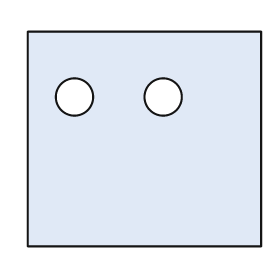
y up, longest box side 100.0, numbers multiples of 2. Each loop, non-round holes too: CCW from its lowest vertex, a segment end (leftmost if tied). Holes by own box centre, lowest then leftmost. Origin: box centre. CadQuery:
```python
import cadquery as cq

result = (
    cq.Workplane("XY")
    .moveTo(-50.0, -46.0)
    .lineTo(50.0, -46.0)
    .lineTo(50.0, 46.0)
    .lineTo(-50.0, 46.0)
    .close()
    .moveTo(-30.0, 18.0)
    .circle(8.0)
    .moveTo(8.0, 18.0)
    .circle(8.0)
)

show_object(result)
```